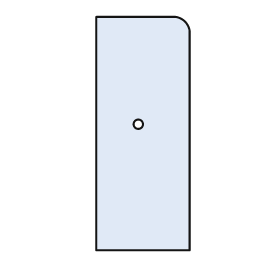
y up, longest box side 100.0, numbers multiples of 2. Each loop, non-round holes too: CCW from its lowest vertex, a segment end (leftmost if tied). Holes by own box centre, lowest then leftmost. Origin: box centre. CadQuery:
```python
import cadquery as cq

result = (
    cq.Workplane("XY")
    .moveTo(-20.0, -50.0)
    .lineTo(20.0, -50.0)
    .lineTo(20.0, 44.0)
    .threePointArc((18.0, 48.0), (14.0, 50.0))
    .lineTo(-20.0, 50.0)
    .close()
    .moveTo(-2.0, 4.0)
    .circle(2.0)
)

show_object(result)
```